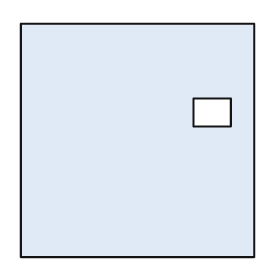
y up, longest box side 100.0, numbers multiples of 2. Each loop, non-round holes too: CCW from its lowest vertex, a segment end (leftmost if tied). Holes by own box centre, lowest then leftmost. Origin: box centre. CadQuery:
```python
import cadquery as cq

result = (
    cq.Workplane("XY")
    .moveTo(-50.0, -50.0)
    .lineTo(50.0, -50.0)
    .lineTo(50.0, 50.0)
    .lineTo(-50.0, 50.0)
    .close()
    .moveTo(24.0, 6.0)
    .lineTo(40.0, 6.0)
    .lineTo(40.0, 18.0)
    .lineTo(24.0, 18.0)
    .close()
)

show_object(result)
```